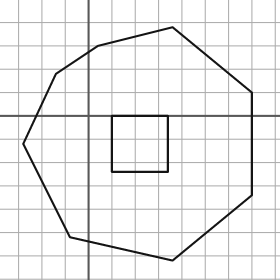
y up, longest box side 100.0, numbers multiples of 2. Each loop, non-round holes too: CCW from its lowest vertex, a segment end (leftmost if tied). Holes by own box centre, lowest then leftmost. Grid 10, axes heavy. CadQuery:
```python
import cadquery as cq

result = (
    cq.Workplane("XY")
    .moveTo(36.0, -62.0)
    .lineTo(70.0, -34.0)
    .lineTo(70.0, 10.0)
    .lineTo(36.0, 38.0)
    .lineTo(4.0, 30.0)
    .lineTo(-14.0, 18.0)
    .lineTo(-28.0, -12.0)
    .lineTo(-8.0, -52.0)
    .close()
    .moveTo(10.0, -24.0)
    .lineTo(34.0, -24.0)
    .lineTo(34.0, 0.0)
    .lineTo(10.0, 0.0)
    .close()
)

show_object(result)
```